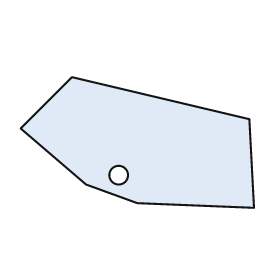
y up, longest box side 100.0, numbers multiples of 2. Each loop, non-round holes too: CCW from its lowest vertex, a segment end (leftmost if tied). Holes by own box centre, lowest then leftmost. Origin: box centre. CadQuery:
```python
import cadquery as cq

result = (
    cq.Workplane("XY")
    .moveTo(50.0, -28.0)
    .lineTo(48.0, 10.0)
    .lineTo(-28.0, 28.0)
    .lineTo(-50.0, 6.0)
    .lineTo(-22.0, -18.0)
    .lineTo(0.0, -26.0)
    .close()
    .moveTo(-8.0, -14.0)
    .circle(4.0)
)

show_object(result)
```